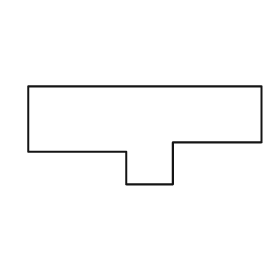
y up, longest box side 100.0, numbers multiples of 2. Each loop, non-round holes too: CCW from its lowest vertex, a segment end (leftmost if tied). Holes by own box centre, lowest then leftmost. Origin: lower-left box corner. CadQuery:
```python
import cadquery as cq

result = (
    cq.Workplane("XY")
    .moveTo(42.0, 0.0)
    .lineTo(62.0, 0.0)
    .lineTo(62.0, 18.0)
    .lineTo(100.0, 18.0)
    .lineTo(100.0, 42.0)
    .lineTo(0.0, 42.0)
    .lineTo(0.0, 14.0)
    .lineTo(42.0, 14.0)
    .close()
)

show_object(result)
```